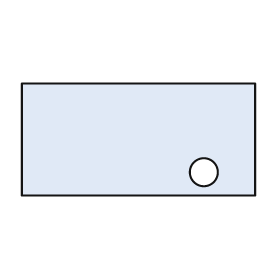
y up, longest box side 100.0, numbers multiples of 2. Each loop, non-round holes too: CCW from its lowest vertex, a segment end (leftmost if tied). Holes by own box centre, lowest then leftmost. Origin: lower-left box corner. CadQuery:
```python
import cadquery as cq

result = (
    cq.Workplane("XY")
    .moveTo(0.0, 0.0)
    .lineTo(100.0, 0.0)
    .lineTo(100.0, 48.0)
    .lineTo(0.0, 48.0)
    .close()
    .moveTo(78.0, 10.0)
    .circle(6.0)
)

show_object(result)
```